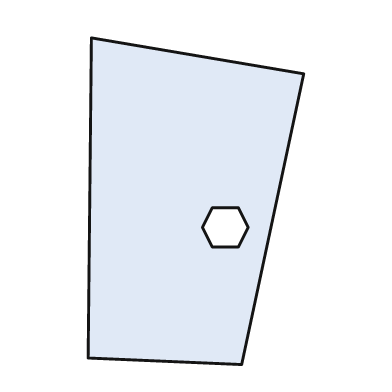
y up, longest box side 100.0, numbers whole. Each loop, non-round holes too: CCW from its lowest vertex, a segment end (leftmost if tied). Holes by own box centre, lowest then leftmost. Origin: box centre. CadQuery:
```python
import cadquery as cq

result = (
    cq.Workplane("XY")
    .moveTo(14.0, -50.0)
    .lineTo(33.0, 39.0)
    .lineTo(-32.0, 50.0)
    .lineTo(-33.0, -48.0)
    .close()
    .moveTo(5.0, -14.0)
    .lineTo(13.0, -14.0)
    .lineTo(16.0, -8.0)
    .lineTo(13.0, -2.0)
    .lineTo(5.0, -2.0)
    .lineTo(2.0, -8.0)
    .close()
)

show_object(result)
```